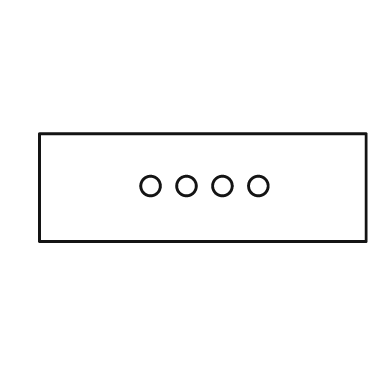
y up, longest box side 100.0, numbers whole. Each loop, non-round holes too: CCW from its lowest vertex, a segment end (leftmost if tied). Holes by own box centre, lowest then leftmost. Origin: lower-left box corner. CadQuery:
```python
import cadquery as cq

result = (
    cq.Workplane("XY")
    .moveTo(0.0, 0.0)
    .lineTo(100.0, 0.0)
    .lineTo(100.0, 33.0)
    .lineTo(0.0, 33.0)
    .close()
    .moveTo(34.0, 17.0)
    .circle(3.0)
    .moveTo(45.0, 17.0)
    .circle(3.0)
    .moveTo(56.0, 17.0)
    .circle(3.0)
    .moveTo(67.0, 17.0)
    .circle(3.0)
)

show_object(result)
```